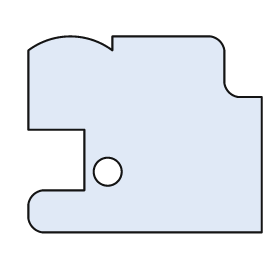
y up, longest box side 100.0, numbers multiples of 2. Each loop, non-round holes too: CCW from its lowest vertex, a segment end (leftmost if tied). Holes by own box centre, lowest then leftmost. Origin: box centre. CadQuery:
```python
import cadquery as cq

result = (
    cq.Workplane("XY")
    .moveTo(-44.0, -42.0)
    .lineTo(50.0, -42.0)
    .lineTo(50.0, 16.0)
    .lineTo(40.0, 16.0)
    .threePointArc((36.0, 18.0), (34.0, 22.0))
    .lineTo(34.0, 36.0)
    .threePointArc((32.0, 40.0), (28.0, 42.0))
    .lineTo(-14.0, 42.0)
    .lineTo(-14.0, 36.0)
    .threePointArc((-32.0, 42.0), (-50.0, 36.0))
    .lineTo(-50.0, 2.0)
    .lineTo(-26.0, 2.0)
    .lineTo(-26.0, -24.0)
    .lineTo(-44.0, -24.0)
    .threePointArc((-48.0, -26.0), (-50.0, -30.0))
    .lineTo(-50.0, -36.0)
    .threePointArc((-48.0, -40.0), (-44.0, -42.0))
    .close()
    .moveTo(-16.0, -16.0)
    .circle(6.0)
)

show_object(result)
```